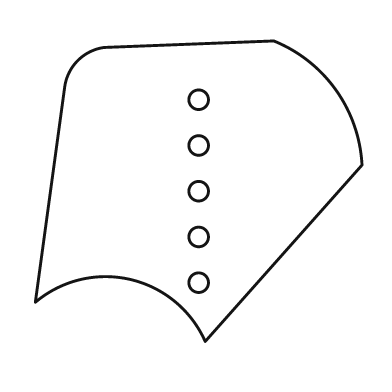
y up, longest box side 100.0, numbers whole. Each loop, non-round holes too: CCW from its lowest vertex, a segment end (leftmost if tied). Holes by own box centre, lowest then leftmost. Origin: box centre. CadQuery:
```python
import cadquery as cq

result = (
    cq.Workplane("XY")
    .moveTo(2.0, -46.0)
    .lineTo(50.0, 8.0)
    .threePointArc((42.0, 31.0), (23.0, 46.0))
    .lineTo(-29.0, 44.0)
    .threePointArc((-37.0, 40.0), (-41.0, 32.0))
    .lineTo(-50.0, -34.0)
    .threePointArc((-21.0, -27.0), (2.0, -46.0))
    .close()
    .moveTo(0.0, -28.0)
    .circle(3.0)
    .moveTo(0.0, -14.0)
    .circle(3.0)
    .moveTo(0.0, 0.0)
    .circle(3.0)
    .moveTo(0.0, 14.0)
    .circle(3.0)
    .moveTo(0.0, 28.0)
    .circle(3.0)
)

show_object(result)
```